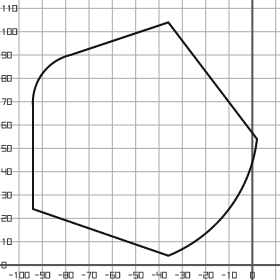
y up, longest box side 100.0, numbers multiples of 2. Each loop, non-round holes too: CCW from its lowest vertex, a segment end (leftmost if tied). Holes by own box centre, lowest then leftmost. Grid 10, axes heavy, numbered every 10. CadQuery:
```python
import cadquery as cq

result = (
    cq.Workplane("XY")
    .moveTo(-36.0, 4.0)
    .threePointArc((-10.0, 24.0), (2.0, 54.0))
    .lineTo(-36.0, 104.0)
    .lineTo(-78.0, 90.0)
    .threePointArc((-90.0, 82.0), (-94.0, 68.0))
    .lineTo(-94.0, 24.0)
    .close()
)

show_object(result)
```